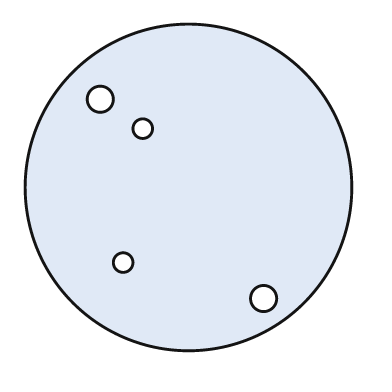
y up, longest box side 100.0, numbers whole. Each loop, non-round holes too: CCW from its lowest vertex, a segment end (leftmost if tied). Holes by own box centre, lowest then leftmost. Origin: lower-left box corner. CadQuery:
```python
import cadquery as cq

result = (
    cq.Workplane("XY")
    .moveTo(50.0, 50.0)
    .circle(50.0)
    .moveTo(73.0, 16.0)
    .circle(4.0)
    .moveTo(30.0, 27.0)
    .circle(3.0)
    .moveTo(36.0, 68.0)
    .circle(3.0)
    .moveTo(23.0, 77.0)
    .circle(4.0)
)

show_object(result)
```